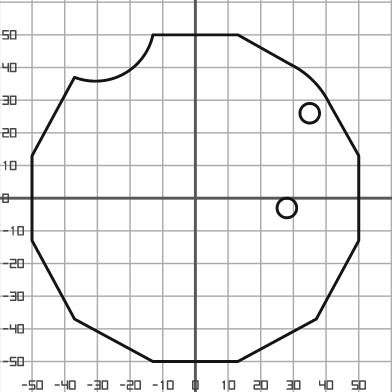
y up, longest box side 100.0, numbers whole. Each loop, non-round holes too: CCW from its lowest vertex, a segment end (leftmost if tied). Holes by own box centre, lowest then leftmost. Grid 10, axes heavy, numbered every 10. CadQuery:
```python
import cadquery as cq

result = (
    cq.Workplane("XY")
    .moveTo(-13.0, -50.0)
    .lineTo(13.0, -50.0)
    .lineTo(37.0, -37.0)
    .lineTo(50.0, -13.0)
    .lineTo(50.0, 13.0)
    .lineTo(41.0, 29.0)
    .threePointArc((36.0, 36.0), (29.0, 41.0))
    .lineTo(13.0, 50.0)
    .lineTo(-13.0, 50.0)
    .threePointArc((-22.0, 38.0), (-37.0, 37.0))
    .lineTo(-50.0, 13.0)
    .lineTo(-50.0, -13.0)
    .lineTo(-37.0, -37.0)
    .close()
    .moveTo(28.0, -3.0)
    .circle(3.0)
    .moveTo(35.0, 26.0)
    .circle(3.0)
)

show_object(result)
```